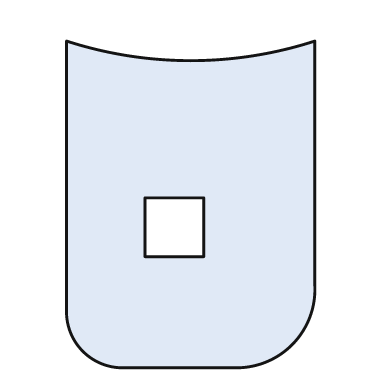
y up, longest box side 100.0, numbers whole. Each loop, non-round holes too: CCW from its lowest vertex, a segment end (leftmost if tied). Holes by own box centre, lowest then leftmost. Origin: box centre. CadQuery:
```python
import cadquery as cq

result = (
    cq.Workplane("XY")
    .moveTo(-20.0, -50.0)
    .lineTo(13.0, -50.0)
    .threePointArc((31.0, -43.0), (38.0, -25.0))
    .lineTo(38.0, 50.0)
    .threePointArc((0.0, 44.0), (-38.0, 50.0))
    .lineTo(-38.0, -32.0)
    .threePointArc((-33.0, -45.0), (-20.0, -50.0))
    .close()
    .moveTo(-14.0, -16.0)
    .lineTo(4.0, -16.0)
    .lineTo(4.0, 2.0)
    .lineTo(-14.0, 2.0)
    .close()
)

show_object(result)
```